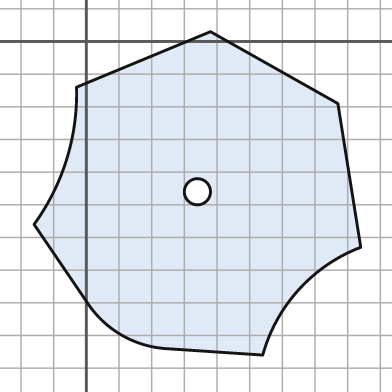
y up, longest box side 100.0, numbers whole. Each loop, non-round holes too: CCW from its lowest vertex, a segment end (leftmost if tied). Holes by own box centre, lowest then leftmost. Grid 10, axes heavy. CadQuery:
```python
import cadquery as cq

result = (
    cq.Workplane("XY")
    .moveTo(54.0, -96.0)
    .threePointArc((65.0, -76.0), (84.0, -63.0))
    .lineTo(77.0, -19.0)
    .lineTo(38.0, 3.0)
    .lineTo(-3.0, -14.0)
    .threePointArc((-6.0, -36.0), (-16.0, -56.0))
    .lineTo(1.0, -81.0)
    .threePointArc((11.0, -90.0), (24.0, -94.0))
    .close()
    .moveTo(34.0, -46.0)
    .circle(4.0)
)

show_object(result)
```